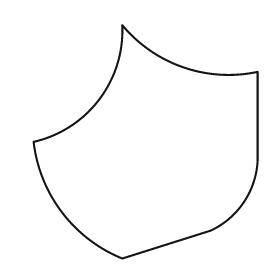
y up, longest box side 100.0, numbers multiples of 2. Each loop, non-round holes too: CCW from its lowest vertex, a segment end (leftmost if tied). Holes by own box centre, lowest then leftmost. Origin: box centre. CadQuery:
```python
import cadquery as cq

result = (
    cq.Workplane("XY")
    .moveTo(-10.0, -50.0)
    .lineTo(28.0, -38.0)
    .threePointArc((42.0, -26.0), (48.0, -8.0))
    .lineTo(48.0, 30.0)
    .threePointArc((16.0, 32.0), (-10.0, 50.0))
    .threePointArc((-20.0, 18.0), (-48.0, 0.0))
    .threePointArc((-36.0, -30.0), (-10.0, -50.0))
    .close()
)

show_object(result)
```